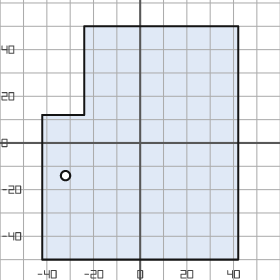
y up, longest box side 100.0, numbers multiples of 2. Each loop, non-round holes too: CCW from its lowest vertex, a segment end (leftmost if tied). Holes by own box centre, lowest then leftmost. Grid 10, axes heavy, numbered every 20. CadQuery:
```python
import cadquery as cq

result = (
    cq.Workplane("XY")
    .moveTo(-42.0, -50.0)
    .lineTo(42.0, -50.0)
    .lineTo(42.0, 50.0)
    .lineTo(-24.0, 50.0)
    .lineTo(-24.0, 12.0)
    .lineTo(-42.0, 12.0)
    .close()
    .moveTo(-32.0, -14.0)
    .circle(2.0)
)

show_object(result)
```